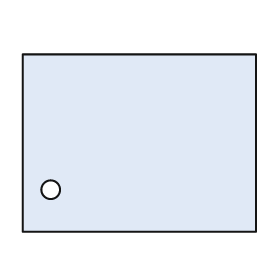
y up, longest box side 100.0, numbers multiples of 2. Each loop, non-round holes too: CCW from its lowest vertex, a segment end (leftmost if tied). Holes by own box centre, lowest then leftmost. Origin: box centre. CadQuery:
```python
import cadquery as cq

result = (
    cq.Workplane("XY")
    .moveTo(-50.0, -38.0)
    .lineTo(50.0, -38.0)
    .lineTo(50.0, 38.0)
    .lineTo(-50.0, 38.0)
    .close()
    .moveTo(-38.0, -20.0)
    .circle(4.0)
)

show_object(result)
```